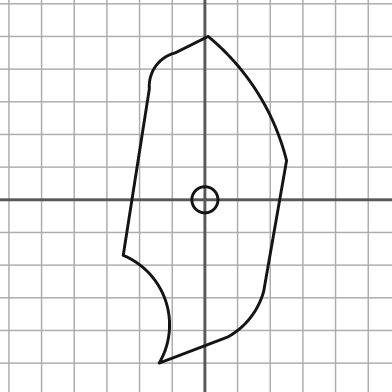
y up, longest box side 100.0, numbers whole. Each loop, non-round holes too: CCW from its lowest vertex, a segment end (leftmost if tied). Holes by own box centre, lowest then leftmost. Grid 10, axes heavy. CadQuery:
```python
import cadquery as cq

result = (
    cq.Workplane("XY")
    .moveTo(-14.0, -50.0)
    .lineTo(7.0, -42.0)
    .threePointArc((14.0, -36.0), (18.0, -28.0))
    .lineTo(25.0, 12.0)
    .threePointArc((16.0, 33.0), (1.0, 50.0))
    .lineTo(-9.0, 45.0)
    .threePointArc((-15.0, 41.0), (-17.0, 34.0))
    .lineTo(-25.0, -17.0)
    .threePointArc((-12.0, -31.0), (-14.0, -50.0))
    .close()
    .moveTo(0.0, 0.0)
    .circle(4.0)
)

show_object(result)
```